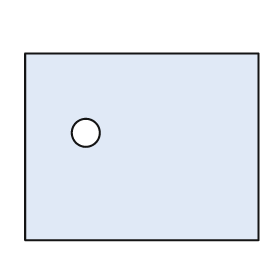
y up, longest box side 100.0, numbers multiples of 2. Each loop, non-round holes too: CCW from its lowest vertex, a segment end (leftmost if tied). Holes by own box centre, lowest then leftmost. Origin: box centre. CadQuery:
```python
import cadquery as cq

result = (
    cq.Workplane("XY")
    .moveTo(-50.0, -40.0)
    .lineTo(50.0, -40.0)
    .lineTo(50.0, 40.0)
    .lineTo(-50.0, 40.0)
    .close()
    .moveTo(-24.0, 6.0)
    .circle(6.0)
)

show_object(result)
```